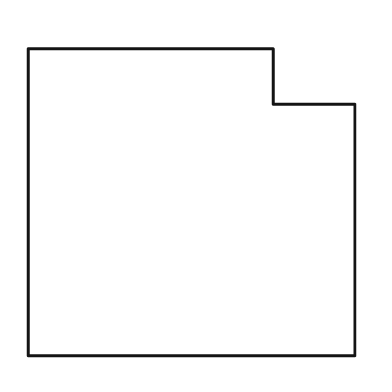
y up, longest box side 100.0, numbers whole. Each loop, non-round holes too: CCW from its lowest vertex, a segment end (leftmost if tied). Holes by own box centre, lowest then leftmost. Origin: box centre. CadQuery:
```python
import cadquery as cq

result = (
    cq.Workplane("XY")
    .moveTo(-50.0, -47.0)
    .lineTo(50.0, -47.0)
    .lineTo(50.0, 30.0)
    .lineTo(25.0, 30.0)
    .lineTo(25.0, 47.0)
    .lineTo(-50.0, 47.0)
    .close()
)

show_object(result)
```